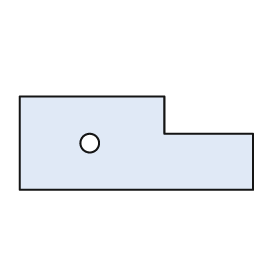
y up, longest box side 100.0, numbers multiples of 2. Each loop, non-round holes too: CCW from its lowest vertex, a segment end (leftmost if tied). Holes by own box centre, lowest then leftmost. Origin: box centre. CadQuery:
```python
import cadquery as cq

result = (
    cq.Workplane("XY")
    .moveTo(-50.0, -20.0)
    .lineTo(50.0, -20.0)
    .lineTo(50.0, 4.0)
    .lineTo(12.0, 4.0)
    .lineTo(12.0, 20.0)
    .lineTo(-50.0, 20.0)
    .close()
    .moveTo(-20.0, 0.0)
    .circle(4.0)
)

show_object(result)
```